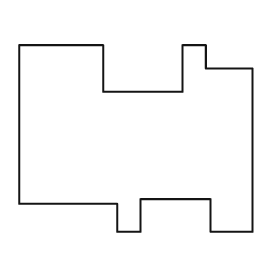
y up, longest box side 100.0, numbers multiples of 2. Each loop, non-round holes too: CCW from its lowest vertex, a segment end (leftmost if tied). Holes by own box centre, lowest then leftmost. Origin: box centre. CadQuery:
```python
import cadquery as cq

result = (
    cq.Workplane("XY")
    .moveTo(-8.0, -40.0)
    .lineTo(2.0, -40.0)
    .lineTo(2.0, -26.0)
    .lineTo(32.0, -26.0)
    .lineTo(32.0, -40.0)
    .lineTo(50.0, -40.0)
    .lineTo(50.0, 30.0)
    .lineTo(30.0, 30.0)
    .lineTo(30.0, 40.0)
    .lineTo(20.0, 40.0)
    .lineTo(20.0, 20.0)
    .lineTo(-14.0, 20.0)
    .lineTo(-14.0, 40.0)
    .lineTo(-50.0, 40.0)
    .lineTo(-50.0, -28.0)
    .lineTo(-8.0, -28.0)
    .close()
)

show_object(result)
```